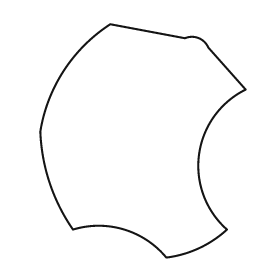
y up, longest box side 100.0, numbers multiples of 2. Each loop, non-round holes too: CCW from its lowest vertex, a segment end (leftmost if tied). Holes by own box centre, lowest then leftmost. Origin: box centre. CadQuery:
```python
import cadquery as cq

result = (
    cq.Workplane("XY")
    .moveTo(10.0, -50.0)
    .threePointArc((24.0, -46.0), (36.0, -38.0))
    .threePointArc((24.0, -6.0), (44.0, 22.0))
    .lineTo(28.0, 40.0)
    .threePointArc((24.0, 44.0), (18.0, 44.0))
    .lineTo(-14.0, 50.0)
    .threePointArc((-34.0, 30.0), (-44.0, 4.0))
    .threePointArc((-40.0, -18.0), (-30.0, -38.0))
    .threePointArc((-8.0, -38.0), (10.0, -50.0))
    .close()
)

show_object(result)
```